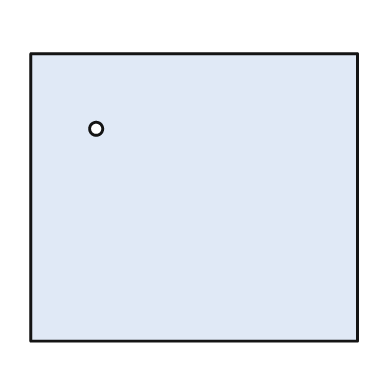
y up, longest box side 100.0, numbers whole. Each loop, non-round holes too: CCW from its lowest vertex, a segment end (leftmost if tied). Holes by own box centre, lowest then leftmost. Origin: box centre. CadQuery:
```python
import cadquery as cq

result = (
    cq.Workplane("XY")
    .moveTo(-50.0, -44.0)
    .lineTo(50.0, -44.0)
    .lineTo(50.0, 44.0)
    .lineTo(-50.0, 44.0)
    .close()
    .moveTo(-30.0, 21.0)
    .circle(2.0)
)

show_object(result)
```